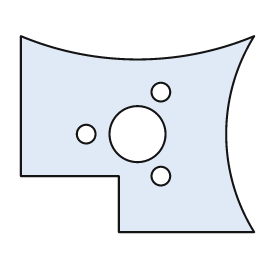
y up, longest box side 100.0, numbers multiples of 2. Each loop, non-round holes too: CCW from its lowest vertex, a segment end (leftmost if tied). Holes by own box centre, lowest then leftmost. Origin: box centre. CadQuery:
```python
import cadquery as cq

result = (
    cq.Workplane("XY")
    .moveTo(-8.0, -42.0)
    .lineTo(50.0, -42.0)
    .threePointArc((38.0, 0.0), (50.0, 42.0))
    .threePointArc((0.0, 32.0), (-50.0, 42.0))
    .lineTo(-50.0, -18.0)
    .lineTo(-8.0, -18.0)
    .close()
    .moveTo(10.0, -18.0)
    .circle(4.0)
    .moveTo(-22.0, 0.0)
    .circle(4.0)
    .moveTo(0.0, 0.0)
    .circle(12.0)
    .moveTo(10.0, 18.0)
    .circle(4.0)
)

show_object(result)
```